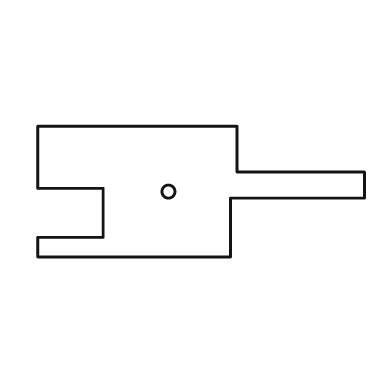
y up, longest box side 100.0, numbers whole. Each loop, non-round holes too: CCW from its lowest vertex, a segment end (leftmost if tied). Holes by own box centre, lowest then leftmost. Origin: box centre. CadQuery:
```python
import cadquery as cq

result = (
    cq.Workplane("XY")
    .moveTo(-50.0, -20.0)
    .lineTo(9.0, -20.0)
    .lineTo(9.0, -2.0)
    .lineTo(50.0, -2.0)
    .lineTo(50.0, 6.0)
    .lineTo(11.0, 6.0)
    .lineTo(11.0, 20.0)
    .lineTo(-50.0, 20.0)
    .lineTo(-50.0, 1.0)
    .lineTo(-30.0, 1.0)
    .lineTo(-30.0, -14.0)
    .lineTo(-50.0, -14.0)
    .close()
    .moveTo(-10.0, 0.0)
    .circle(2.0)
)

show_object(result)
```